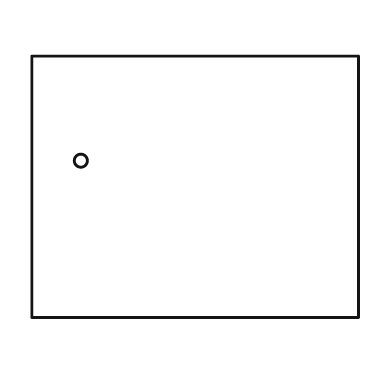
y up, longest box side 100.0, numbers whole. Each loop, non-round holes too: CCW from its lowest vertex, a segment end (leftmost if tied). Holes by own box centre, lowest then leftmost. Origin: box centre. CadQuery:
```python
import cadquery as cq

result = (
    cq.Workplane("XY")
    .moveTo(-50.0, -40.0)
    .lineTo(50.0, -40.0)
    .lineTo(50.0, 40.0)
    .lineTo(-50.0, 40.0)
    .close()
    .moveTo(-35.0, 8.0)
    .circle(2.0)
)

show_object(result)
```